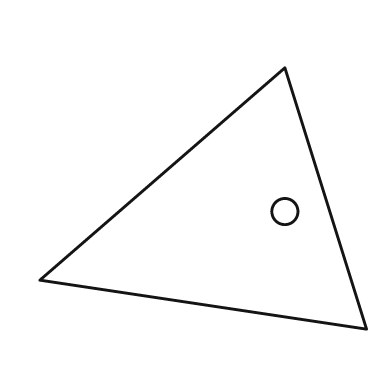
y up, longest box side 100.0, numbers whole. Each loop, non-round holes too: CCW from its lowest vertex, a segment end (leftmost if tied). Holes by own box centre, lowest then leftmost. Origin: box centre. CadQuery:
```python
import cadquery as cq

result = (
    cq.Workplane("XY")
    .moveTo(50.0, -40.0)
    .lineTo(25.0, 40.0)
    .lineTo(-50.0, -25.0)
    .close()
    .moveTo(25.0, -4.0)
    .circle(4.0)
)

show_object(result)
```